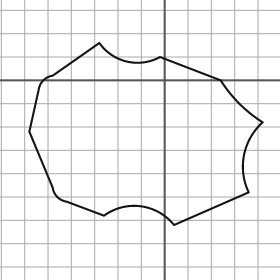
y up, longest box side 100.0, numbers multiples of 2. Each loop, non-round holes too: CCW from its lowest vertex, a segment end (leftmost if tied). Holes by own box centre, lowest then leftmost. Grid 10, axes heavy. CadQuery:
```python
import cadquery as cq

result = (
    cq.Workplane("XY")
    .moveTo(4.0, -62.0)
    .lineTo(36.0, -48.0)
    .threePointArc((34.0, -32.0), (42.0, -18.0))
    .threePointArc((32.0, -10.0), (24.0, 0.0))
    .lineTo(-2.0, 10.0)
    .threePointArc((-16.0, 8.0), (-28.0, 16.0))
    .lineTo(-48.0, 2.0)
    .threePointArc((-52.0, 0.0), (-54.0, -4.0))
    .lineTo(-58.0, -22.0)
    .lineTo(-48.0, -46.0)
    .threePointArc((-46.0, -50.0), (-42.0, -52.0))
    .lineTo(-26.0, -58.0)
    .threePointArc((-10.0, -54.0), (4.0, -62.0))
    .close()
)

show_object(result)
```